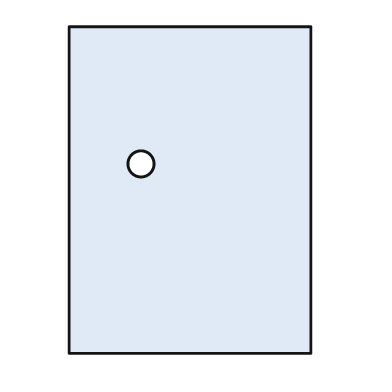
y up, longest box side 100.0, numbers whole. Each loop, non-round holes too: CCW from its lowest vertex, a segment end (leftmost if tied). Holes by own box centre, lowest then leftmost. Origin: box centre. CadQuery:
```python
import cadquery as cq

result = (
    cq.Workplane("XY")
    .moveTo(-37.0, -50.0)
    .lineTo(37.0, -50.0)
    .lineTo(37.0, 50.0)
    .lineTo(-37.0, 50.0)
    .close()
    .moveTo(-15.0, 8.0)
    .circle(4.0)
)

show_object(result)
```